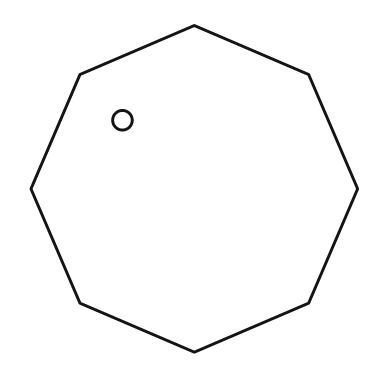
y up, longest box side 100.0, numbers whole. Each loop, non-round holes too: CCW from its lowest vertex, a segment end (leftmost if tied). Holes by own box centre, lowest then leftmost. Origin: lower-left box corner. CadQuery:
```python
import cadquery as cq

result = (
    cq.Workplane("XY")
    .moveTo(50.0, 0.0)
    .lineTo(85.0, 15.0)
    .lineTo(100.0, 50.0)
    .lineTo(85.0, 85.0)
    .lineTo(50.0, 100.0)
    .lineTo(15.0, 85.0)
    .lineTo(0.0, 50.0)
    .lineTo(15.0, 15.0)
    .close()
    .moveTo(28.0, 71.0)
    .circle(3.0)
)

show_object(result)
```